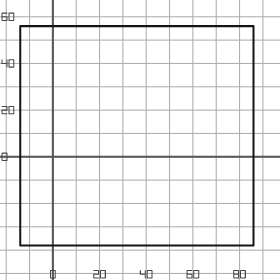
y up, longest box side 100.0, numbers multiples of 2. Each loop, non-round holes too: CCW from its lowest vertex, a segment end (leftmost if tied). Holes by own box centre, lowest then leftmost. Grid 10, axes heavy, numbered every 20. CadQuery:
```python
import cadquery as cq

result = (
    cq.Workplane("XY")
    .moveTo(-14.0, -38.0)
    .lineTo(86.0, -38.0)
    .lineTo(86.0, 56.0)
    .lineTo(-14.0, 56.0)
    .close()
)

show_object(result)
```